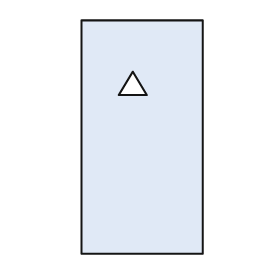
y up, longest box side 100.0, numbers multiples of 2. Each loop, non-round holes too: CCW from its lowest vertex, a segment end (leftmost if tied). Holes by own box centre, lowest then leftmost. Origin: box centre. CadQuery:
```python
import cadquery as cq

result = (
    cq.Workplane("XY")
    .moveTo(-26.0, -50.0)
    .lineTo(26.0, -50.0)
    .lineTo(26.0, 50.0)
    .lineTo(-26.0, 50.0)
    .close()
    .moveTo(-10.0, 18.0)
    .lineTo(2.0, 18.0)
    .lineTo(-4.0, 28.0)
    .close()
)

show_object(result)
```